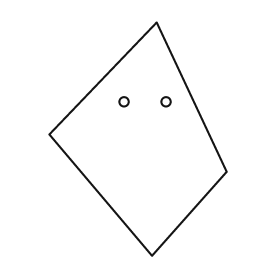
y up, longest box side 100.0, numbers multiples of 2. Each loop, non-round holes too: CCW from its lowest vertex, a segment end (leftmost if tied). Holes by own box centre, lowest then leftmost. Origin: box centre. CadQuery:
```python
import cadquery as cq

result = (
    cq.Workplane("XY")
    .moveTo(6.0, -50.0)
    .lineTo(38.0, -14.0)
    .lineTo(8.0, 50.0)
    .lineTo(-38.0, 2.0)
    .close()
    .moveTo(-6.0, 16.0)
    .circle(2.0)
    .moveTo(12.0, 16.0)
    .circle(2.0)
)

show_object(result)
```